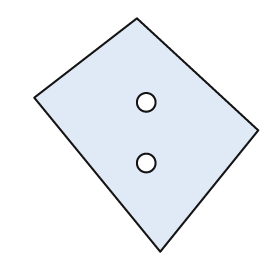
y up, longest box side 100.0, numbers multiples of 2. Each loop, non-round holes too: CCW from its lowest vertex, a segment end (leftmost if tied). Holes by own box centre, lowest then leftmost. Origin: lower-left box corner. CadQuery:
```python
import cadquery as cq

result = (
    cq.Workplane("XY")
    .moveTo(54.0, 0.0)
    .lineTo(96.0, 52.0)
    .lineTo(44.0, 100.0)
    .lineTo(0.0, 66.0)
    .close()
    .moveTo(48.0, 38.0)
    .circle(4.0)
    .moveTo(48.0, 64.0)
    .circle(4.0)
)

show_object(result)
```